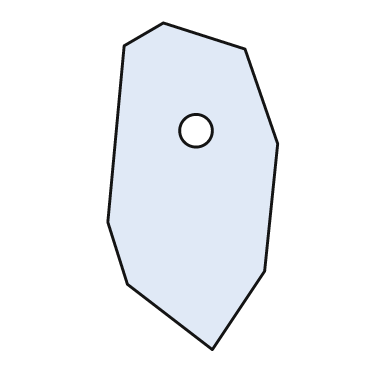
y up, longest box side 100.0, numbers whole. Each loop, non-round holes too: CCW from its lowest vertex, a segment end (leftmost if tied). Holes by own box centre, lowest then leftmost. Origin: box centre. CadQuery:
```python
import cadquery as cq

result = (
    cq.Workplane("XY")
    .moveTo(6.0, -50.0)
    .lineTo(22.0, -26.0)
    .lineTo(26.0, 13.0)
    .lineTo(16.0, 42.0)
    .lineTo(-9.0, 50.0)
    .lineTo(-21.0, 43.0)
    .lineTo(-26.0, -11.0)
    .lineTo(-20.0, -30.0)
    .close()
    .moveTo(1.0, 17.0)
    .circle(5.0)
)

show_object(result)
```